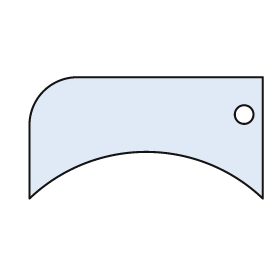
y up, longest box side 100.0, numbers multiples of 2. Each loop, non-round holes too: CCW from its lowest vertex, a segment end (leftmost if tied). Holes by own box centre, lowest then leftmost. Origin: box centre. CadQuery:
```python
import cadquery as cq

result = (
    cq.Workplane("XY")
    .moveTo(-50.0, -26.0)
    .threePointArc((0.0, -6.0), (50.0, -26.0))
    .lineTo(50.0, 26.0)
    .lineTo(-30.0, 26.0)
    .threePointArc((-44.0, 20.0), (-50.0, 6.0))
    .close()
    .moveTo(42.0, 10.0)
    .circle(4.0)
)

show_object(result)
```